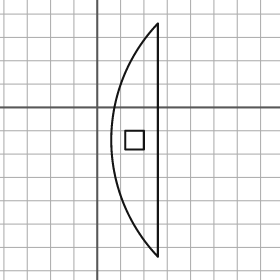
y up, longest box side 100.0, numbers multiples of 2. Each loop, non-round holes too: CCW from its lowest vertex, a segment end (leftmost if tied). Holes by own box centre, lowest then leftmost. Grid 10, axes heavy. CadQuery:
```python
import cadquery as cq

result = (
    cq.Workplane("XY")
    .moveTo(26.0, -64.0)
    .lineTo(26.0, 36.0)
    .threePointArc((6.0, -14.0), (26.0, -64.0))
    .close()
    .moveTo(12.0, -18.0)
    .lineTo(20.0, -18.0)
    .lineTo(20.0, -10.0)
    .lineTo(12.0, -10.0)
    .close()
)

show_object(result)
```